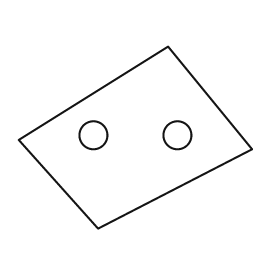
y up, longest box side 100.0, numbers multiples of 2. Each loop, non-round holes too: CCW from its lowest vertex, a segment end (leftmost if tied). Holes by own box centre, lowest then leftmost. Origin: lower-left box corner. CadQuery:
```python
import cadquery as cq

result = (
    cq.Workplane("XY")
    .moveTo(34.0, 0.0)
    .lineTo(100.0, 34.0)
    .lineTo(64.0, 78.0)
    .lineTo(0.0, 38.0)
    .close()
    .moveTo(32.0, 40.0)
    .circle(6.0)
    .moveTo(68.0, 40.0)
    .circle(6.0)
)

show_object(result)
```